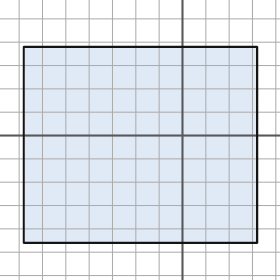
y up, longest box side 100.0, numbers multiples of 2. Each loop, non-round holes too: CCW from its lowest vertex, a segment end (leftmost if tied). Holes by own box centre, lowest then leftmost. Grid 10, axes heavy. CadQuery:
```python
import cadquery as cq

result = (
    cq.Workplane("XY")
    .moveTo(-68.0, -46.0)
    .lineTo(32.0, -46.0)
    .lineTo(32.0, 38.0)
    .lineTo(-68.0, 38.0)
    .close()
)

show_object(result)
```